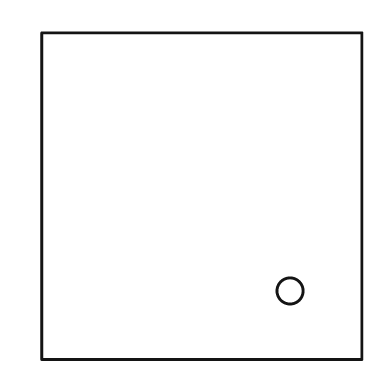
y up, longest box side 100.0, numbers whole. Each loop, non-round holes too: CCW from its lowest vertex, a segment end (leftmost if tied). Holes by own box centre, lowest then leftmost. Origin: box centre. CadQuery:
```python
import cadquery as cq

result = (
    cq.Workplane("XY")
    .moveTo(-49.0, -50.0)
    .lineTo(49.0, -50.0)
    .lineTo(49.0, 50.0)
    .lineTo(-49.0, 50.0)
    .close()
    .moveTo(27.0, -29.0)
    .circle(4.0)
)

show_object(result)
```